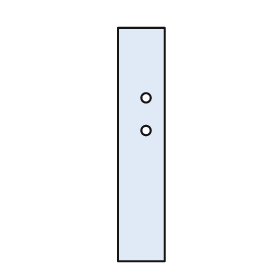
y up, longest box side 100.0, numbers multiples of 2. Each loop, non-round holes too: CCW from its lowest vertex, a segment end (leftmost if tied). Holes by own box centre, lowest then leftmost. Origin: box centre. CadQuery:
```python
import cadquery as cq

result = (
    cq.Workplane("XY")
    .moveTo(-10.0, -50.0)
    .lineTo(10.0, -50.0)
    .lineTo(10.0, 50.0)
    .lineTo(-10.0, 50.0)
    .close()
    .moveTo(2.0, 6.0)
    .circle(2.0)
    .moveTo(2.0, 20.0)
    .circle(2.0)
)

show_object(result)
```